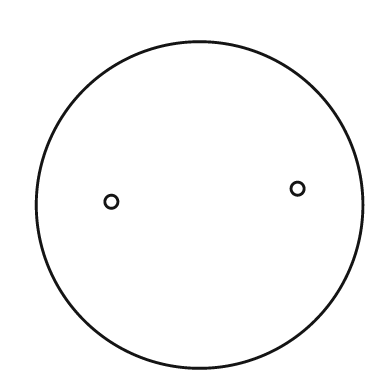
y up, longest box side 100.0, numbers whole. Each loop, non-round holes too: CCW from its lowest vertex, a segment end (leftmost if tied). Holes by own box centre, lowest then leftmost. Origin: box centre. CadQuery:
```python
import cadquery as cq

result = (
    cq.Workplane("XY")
    .moveTo(0.0, 0.0)
    .circle(50.0)
    .moveTo(-27.0, 1.0)
    .circle(2.0)
    .moveTo(30.0, 5.0)
    .circle(2.0)
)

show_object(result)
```